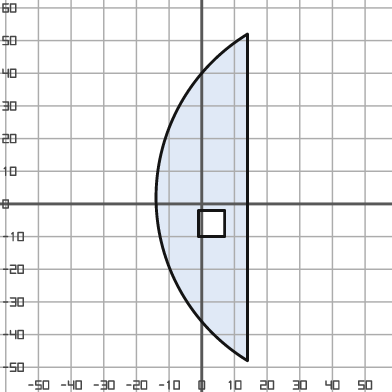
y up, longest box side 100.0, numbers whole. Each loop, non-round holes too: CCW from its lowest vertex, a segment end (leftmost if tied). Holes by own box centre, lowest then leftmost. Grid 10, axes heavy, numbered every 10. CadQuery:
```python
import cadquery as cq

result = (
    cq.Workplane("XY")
    .moveTo(14.0, -48.0)
    .lineTo(14.0, 52.0)
    .threePointArc((-14.0, 2.0), (14.0, -48.0))
    .close()
    .moveTo(-1.0, -10.0)
    .lineTo(7.0, -10.0)
    .lineTo(7.0, -2.0)
    .lineTo(-1.0, -2.0)
    .close()
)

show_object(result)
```